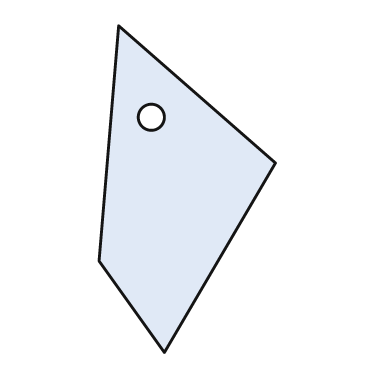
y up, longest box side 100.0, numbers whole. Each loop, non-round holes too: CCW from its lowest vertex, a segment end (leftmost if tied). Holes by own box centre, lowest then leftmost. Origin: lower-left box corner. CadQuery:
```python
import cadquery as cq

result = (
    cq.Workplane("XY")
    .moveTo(20.0, 0.0)
    .lineTo(54.0, 58.0)
    .lineTo(6.0, 100.0)
    .lineTo(0.0, 28.0)
    .close()
    .moveTo(16.0, 72.0)
    .circle(4.0)
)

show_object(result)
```